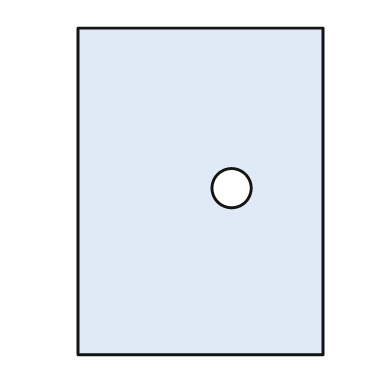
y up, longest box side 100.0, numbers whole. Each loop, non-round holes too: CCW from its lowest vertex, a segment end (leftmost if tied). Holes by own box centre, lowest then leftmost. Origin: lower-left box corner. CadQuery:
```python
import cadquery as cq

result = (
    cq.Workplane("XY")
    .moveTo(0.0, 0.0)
    .lineTo(75.0, 0.0)
    .lineTo(75.0, 100.0)
    .lineTo(0.0, 100.0)
    .close()
    .moveTo(47.0, 51.0)
    .circle(6.0)
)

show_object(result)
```